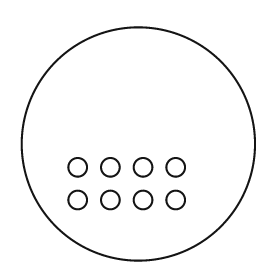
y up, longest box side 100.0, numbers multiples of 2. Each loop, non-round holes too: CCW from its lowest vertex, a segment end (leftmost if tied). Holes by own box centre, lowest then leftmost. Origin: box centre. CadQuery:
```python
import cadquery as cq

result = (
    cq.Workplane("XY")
    .moveTo(0.0, 0.0)
    .circle(50.0)
    .moveTo(-26.0, -24.0)
    .circle(4.0)
    .moveTo(-12.0, -24.0)
    .circle(4.0)
    .moveTo(2.0, -24.0)
    .circle(4.0)
    .moveTo(16.0, -24.0)
    .circle(4.0)
    .moveTo(-26.0, -10.0)
    .circle(4.0)
    .moveTo(-12.0, -10.0)
    .circle(4.0)
    .moveTo(2.0, -10.0)
    .circle(4.0)
    .moveTo(16.0, -10.0)
    .circle(4.0)
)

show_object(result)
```